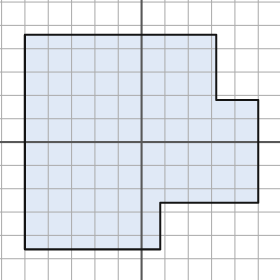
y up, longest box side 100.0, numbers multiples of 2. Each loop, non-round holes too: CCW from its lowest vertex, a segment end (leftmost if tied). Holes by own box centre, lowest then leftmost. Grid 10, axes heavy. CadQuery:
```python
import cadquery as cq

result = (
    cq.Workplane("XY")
    .moveTo(-50.0, -46.0)
    .lineTo(8.0, -46.0)
    .lineTo(8.0, -26.0)
    .lineTo(50.0, -26.0)
    .lineTo(50.0, 18.0)
    .lineTo(32.0, 18.0)
    .lineTo(32.0, 46.0)
    .lineTo(-50.0, 46.0)
    .close()
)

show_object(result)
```